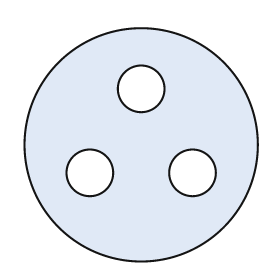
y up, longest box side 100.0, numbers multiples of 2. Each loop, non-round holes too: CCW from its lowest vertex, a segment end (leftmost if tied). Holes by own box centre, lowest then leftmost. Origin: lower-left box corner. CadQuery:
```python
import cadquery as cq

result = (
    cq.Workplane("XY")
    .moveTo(50.0, 50.0)
    .circle(50.0)
    .moveTo(28.0, 38.0)
    .circle(10.0)
    .moveTo(72.0, 38.0)
    .circle(10.0)
    .moveTo(50.0, 74.0)
    .circle(10.0)
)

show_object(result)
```